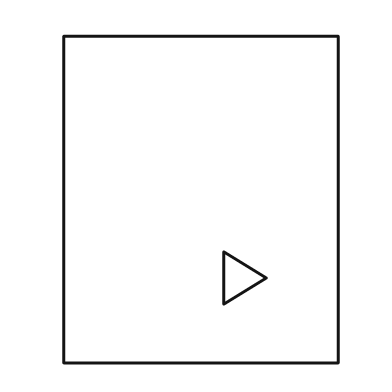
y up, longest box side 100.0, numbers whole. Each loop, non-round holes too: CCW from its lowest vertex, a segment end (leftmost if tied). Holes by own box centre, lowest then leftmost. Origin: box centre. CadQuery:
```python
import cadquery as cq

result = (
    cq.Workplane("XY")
    .moveTo(-42.0, -50.0)
    .lineTo(42.0, -50.0)
    .lineTo(42.0, 50.0)
    .lineTo(-42.0, 50.0)
    .close()
    .moveTo(7.0, -32.0)
    .lineTo(20.0, -24.0)
    .lineTo(7.0, -16.0)
    .close()
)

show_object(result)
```